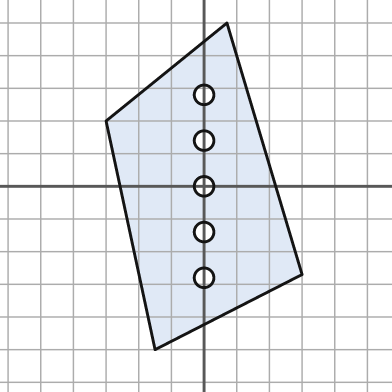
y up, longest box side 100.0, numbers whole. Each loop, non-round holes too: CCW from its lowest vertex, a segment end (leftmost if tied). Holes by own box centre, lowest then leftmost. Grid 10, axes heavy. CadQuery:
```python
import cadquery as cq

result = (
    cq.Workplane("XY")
    .moveTo(-15.0, -50.0)
    .lineTo(30.0, -27.0)
    .lineTo(7.0, 50.0)
    .lineTo(-30.0, 20.0)
    .close()
    .moveTo(0.0, -28.0)
    .circle(3.0)
    .moveTo(0.0, -14.0)
    .circle(3.0)
    .moveTo(0.0, 0.0)
    .circle(3.0)
    .moveTo(0.0, 14.0)
    .circle(3.0)
    .moveTo(0.0, 28.0)
    .circle(3.0)
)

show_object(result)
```